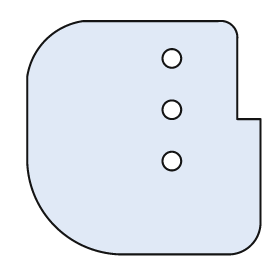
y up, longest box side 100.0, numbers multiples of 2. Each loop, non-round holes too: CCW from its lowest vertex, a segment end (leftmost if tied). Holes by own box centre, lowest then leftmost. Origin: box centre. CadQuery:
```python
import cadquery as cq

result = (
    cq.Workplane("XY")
    .moveTo(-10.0, -50.0)
    .lineTo(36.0, -50.0)
    .threePointArc((46.0, -46.0), (50.0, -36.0))
    .lineTo(50.0, 8.0)
    .lineTo(40.0, 8.0)
    .lineTo(40.0, 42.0)
    .threePointArc((38.0, 48.0), (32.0, 50.0))
    .lineTo(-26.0, 50.0)
    .threePointArc((-42.0, 42.0), (-50.0, 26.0))
    .lineTo(-50.0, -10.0)
    .threePointArc((-38.0, -38.0), (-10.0, -50.0))
    .close()
    .moveTo(12.0, -10.0)
    .circle(4.0)
    .moveTo(12.0, 12.0)
    .circle(4.0)
    .moveTo(12.0, 34.0)
    .circle(4.0)
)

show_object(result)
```